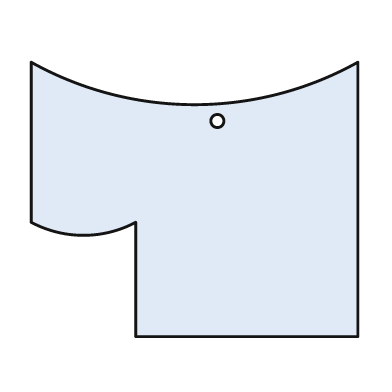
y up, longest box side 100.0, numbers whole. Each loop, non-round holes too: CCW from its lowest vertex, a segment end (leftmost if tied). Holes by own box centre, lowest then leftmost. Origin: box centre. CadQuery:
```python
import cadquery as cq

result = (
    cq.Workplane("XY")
    .moveTo(-18.0, -42.0)
    .lineTo(50.0, -42.0)
    .lineTo(50.0, 42.0)
    .threePointArc((0.0, 29.0), (-50.0, 42.0))
    .lineTo(-50.0, -7.0)
    .threePointArc((-34.0, -11.0), (-18.0, -7.0))
    .close()
    .moveTo(7.0, 24.0)
    .circle(2.0)
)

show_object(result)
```